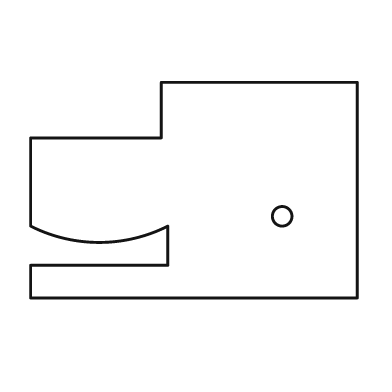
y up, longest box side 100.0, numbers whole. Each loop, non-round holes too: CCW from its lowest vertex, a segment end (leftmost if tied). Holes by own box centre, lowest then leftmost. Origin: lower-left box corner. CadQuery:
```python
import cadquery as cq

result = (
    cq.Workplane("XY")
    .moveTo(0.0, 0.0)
    .lineTo(100.0, 0.0)
    .lineTo(100.0, 66.0)
    .lineTo(40.0, 66.0)
    .lineTo(40.0, 49.0)
    .lineTo(0.0, 49.0)
    .lineTo(0.0, 22.0)
    .threePointArc((21.0, 17.0), (42.0, 22.0))
    .lineTo(42.0, 10.0)
    .lineTo(0.0, 10.0)
    .close()
    .moveTo(77.0, 25.0)
    .circle(3.0)
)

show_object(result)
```